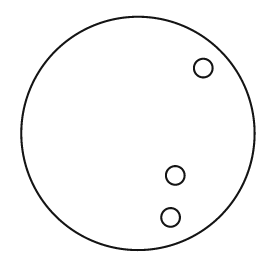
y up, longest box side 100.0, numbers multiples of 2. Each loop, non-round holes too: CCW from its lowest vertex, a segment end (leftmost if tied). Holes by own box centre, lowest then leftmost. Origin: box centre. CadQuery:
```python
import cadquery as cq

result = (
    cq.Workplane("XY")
    .moveTo(0.0, 0.0)
    .circle(50.0)
    .moveTo(14.0, -36.0)
    .circle(4.0)
    .moveTo(16.0, -18.0)
    .circle(4.0)
    .moveTo(28.0, 28.0)
    .circle(4.0)
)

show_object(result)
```